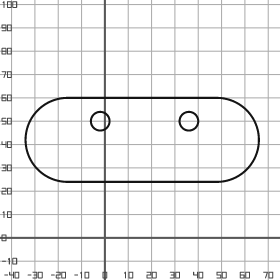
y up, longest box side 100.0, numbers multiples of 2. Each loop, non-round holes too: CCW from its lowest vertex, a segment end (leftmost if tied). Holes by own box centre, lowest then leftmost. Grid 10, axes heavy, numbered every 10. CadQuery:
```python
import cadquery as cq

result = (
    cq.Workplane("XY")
    .moveTo(-16.0, 24.0)
    .lineTo(48.0, 24.0)
    .threePointArc((66.0, 42.0), (48.0, 60.0))
    .lineTo(-16.0, 60.0)
    .threePointArc((-34.0, 42.0), (-16.0, 24.0))
    .close()
    .moveTo(-2.0, 50.0)
    .circle(4.0)
    .moveTo(36.0, 50.0)
    .circle(4.0)
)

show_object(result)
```